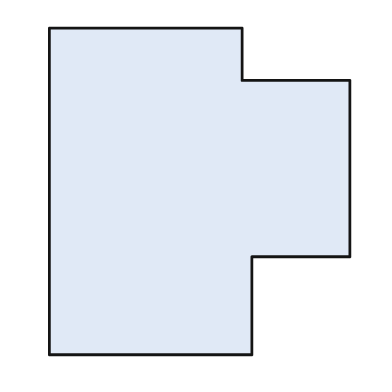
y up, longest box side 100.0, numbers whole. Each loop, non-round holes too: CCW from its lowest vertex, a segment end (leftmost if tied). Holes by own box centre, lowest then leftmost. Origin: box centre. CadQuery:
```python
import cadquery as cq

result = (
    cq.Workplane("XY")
    .moveTo(-46.0, -50.0)
    .lineTo(16.0, -50.0)
    .lineTo(16.0, -20.0)
    .lineTo(46.0, -20.0)
    .lineTo(46.0, 34.0)
    .lineTo(13.0, 34.0)
    .lineTo(13.0, 50.0)
    .lineTo(-46.0, 50.0)
    .close()
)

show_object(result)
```